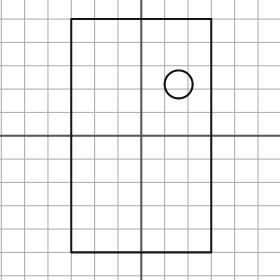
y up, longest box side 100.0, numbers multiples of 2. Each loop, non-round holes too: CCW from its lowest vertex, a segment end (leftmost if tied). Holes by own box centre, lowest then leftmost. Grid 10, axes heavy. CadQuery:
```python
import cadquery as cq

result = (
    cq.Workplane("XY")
    .moveTo(-30.0, -50.0)
    .lineTo(30.0, -50.0)
    .lineTo(30.0, 50.0)
    .lineTo(-30.0, 50.0)
    .close()
    .moveTo(16.0, 22.0)
    .circle(6.0)
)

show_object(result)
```